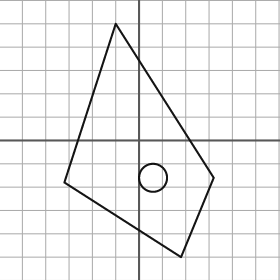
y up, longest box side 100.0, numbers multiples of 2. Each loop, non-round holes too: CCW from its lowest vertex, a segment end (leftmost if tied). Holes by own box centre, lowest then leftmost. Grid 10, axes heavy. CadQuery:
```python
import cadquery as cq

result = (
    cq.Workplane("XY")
    .moveTo(18.0, -50.0)
    .lineTo(32.0, -16.0)
    .lineTo(-10.0, 50.0)
    .lineTo(-32.0, -18.0)
    .close()
    .moveTo(6.0, -16.0)
    .circle(6.0)
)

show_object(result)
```